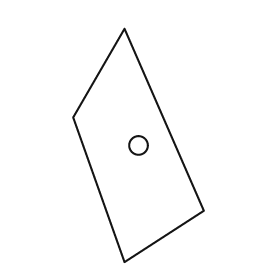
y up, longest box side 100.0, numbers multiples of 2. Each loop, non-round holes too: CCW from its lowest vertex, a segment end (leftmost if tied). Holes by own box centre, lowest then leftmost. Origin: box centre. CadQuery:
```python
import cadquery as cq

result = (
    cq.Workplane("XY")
    .moveTo(-6.0, -50.0)
    .lineTo(28.0, -28.0)
    .lineTo(-6.0, 50.0)
    .lineTo(-28.0, 12.0)
    .close()
    .moveTo(0.0, 0.0)
    .circle(4.0)
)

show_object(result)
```